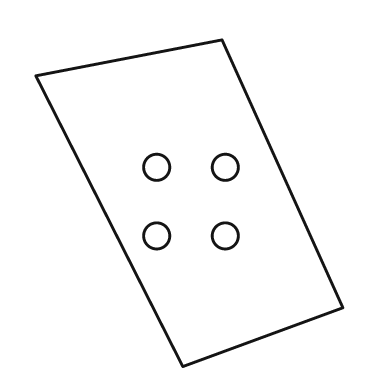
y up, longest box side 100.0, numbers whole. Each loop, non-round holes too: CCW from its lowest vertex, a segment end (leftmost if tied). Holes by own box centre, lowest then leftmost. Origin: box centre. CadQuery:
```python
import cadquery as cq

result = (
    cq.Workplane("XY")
    .moveTo(-2.0, -50.0)
    .lineTo(47.0, -32.0)
    .lineTo(10.0, 50.0)
    .lineTo(-47.0, 39.0)
    .close()
    .moveTo(-10.0, -10.0)
    .circle(4.0)
    .moveTo(11.0, -10.0)
    .circle(4.0)
    .moveTo(-10.0, 11.0)
    .circle(4.0)
    .moveTo(11.0, 11.0)
    .circle(4.0)
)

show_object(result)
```